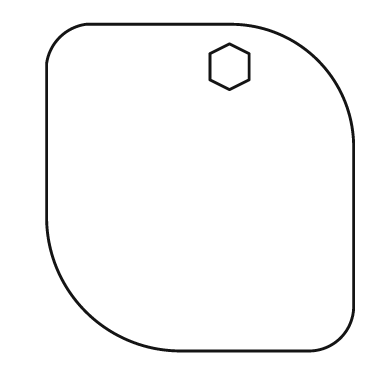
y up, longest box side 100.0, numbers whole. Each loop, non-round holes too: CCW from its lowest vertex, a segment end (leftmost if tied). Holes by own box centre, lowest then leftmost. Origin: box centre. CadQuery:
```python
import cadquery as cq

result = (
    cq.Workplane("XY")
    .moveTo(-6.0, -50.0)
    .lineTo(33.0, -50.0)
    .threePointArc((43.0, -46.0), (47.0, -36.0))
    .lineTo(47.0, 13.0)
    .threePointArc((36.0, 39.0), (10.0, 50.0))
    .lineTo(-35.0, 50.0)
    .threePointArc((-43.0, 46.0), (-47.0, 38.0))
    .lineTo(-47.0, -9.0)
    .threePointArc((-35.0, -38.0), (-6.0, -50.0))
    .close()
    .moveTo(9.0, 30.0)
    .lineTo(15.0, 33.0)
    .lineTo(15.0, 41.0)
    .lineTo(9.0, 44.0)
    .lineTo(3.0, 41.0)
    .lineTo(3.0, 33.0)
    .close()
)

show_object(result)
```